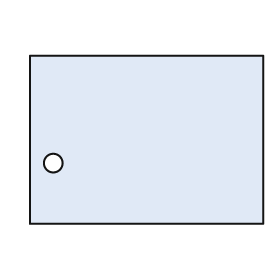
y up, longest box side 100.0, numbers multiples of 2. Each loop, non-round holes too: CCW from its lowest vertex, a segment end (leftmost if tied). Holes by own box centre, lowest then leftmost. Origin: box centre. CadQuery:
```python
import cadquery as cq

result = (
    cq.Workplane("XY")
    .moveTo(-50.0, -36.0)
    .lineTo(50.0, -36.0)
    .lineTo(50.0, 36.0)
    .lineTo(-50.0, 36.0)
    .close()
    .moveTo(-40.0, -10.0)
    .circle(4.0)
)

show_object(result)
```